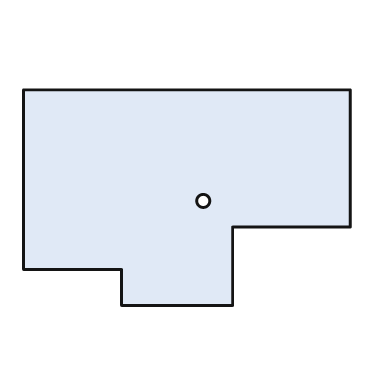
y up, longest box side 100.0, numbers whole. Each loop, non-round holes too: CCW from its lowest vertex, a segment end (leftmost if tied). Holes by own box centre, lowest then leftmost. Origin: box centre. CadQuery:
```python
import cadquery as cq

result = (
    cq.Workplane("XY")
    .moveTo(-20.0, -33.0)
    .lineTo(14.0, -33.0)
    .lineTo(14.0, -9.0)
    .lineTo(50.0, -9.0)
    .lineTo(50.0, 33.0)
    .lineTo(-50.0, 33.0)
    .lineTo(-50.0, -22.0)
    .lineTo(-20.0, -22.0)
    .close()
    .moveTo(5.0, -1.0)
    .circle(2.0)
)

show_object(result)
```